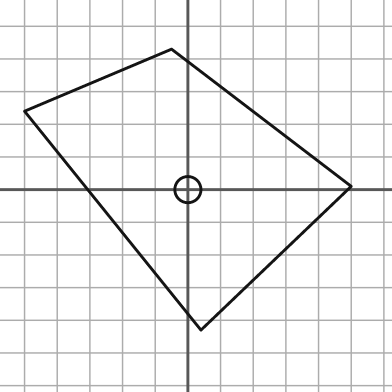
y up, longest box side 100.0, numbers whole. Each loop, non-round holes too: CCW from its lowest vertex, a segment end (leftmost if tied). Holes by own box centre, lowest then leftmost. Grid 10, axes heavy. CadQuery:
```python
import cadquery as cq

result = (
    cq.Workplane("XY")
    .moveTo(4.0, -43.0)
    .lineTo(50.0, 1.0)
    .lineTo(-5.0, 43.0)
    .lineTo(-50.0, 24.0)
    .close()
    .moveTo(0.0, 0.0)
    .circle(4.0)
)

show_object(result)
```